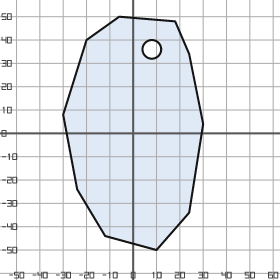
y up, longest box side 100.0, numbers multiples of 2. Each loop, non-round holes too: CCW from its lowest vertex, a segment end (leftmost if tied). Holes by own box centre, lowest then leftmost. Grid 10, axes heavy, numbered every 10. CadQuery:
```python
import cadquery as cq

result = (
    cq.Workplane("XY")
    .moveTo(10.0, -50.0)
    .lineTo(24.0, -34.0)
    .lineTo(30.0, 4.0)
    .lineTo(24.0, 34.0)
    .lineTo(18.0, 48.0)
    .lineTo(-6.0, 50.0)
    .lineTo(-20.0, 40.0)
    .lineTo(-30.0, 8.0)
    .lineTo(-24.0, -24.0)
    .lineTo(-12.0, -44.0)
    .close()
    .moveTo(8.0, 36.0)
    .circle(4.0)
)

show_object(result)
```